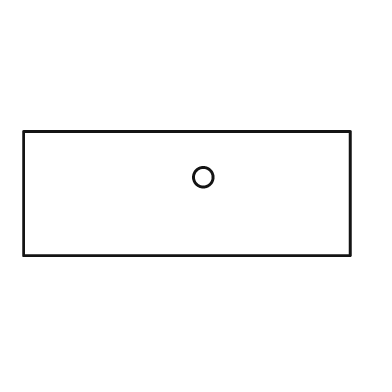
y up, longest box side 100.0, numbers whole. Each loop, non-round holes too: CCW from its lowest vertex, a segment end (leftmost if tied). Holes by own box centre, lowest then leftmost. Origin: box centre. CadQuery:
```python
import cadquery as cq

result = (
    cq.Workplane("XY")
    .moveTo(-50.0, -19.0)
    .lineTo(50.0, -19.0)
    .lineTo(50.0, 19.0)
    .lineTo(-50.0, 19.0)
    .close()
    .moveTo(5.0, 5.0)
    .circle(3.0)
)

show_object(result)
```